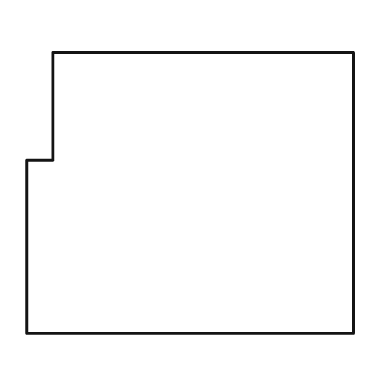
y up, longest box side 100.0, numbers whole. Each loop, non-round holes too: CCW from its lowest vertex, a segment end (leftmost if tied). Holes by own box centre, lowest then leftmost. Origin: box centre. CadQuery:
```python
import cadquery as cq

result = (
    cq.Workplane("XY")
    .moveTo(-50.0, -43.0)
    .lineTo(50.0, -43.0)
    .lineTo(50.0, 43.0)
    .lineTo(-42.0, 43.0)
    .lineTo(-42.0, 10.0)
    .lineTo(-50.0, 10.0)
    .close()
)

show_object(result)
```